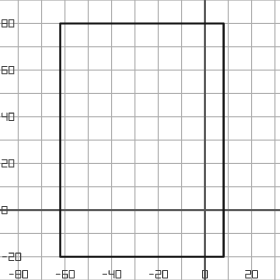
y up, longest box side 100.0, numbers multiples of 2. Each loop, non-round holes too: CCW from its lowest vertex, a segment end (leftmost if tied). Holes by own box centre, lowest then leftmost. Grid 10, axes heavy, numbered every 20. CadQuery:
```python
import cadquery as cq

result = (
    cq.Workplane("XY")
    .moveTo(-62.0, -20.0)
    .lineTo(8.0, -20.0)
    .lineTo(8.0, 80.0)
    .lineTo(-62.0, 80.0)
    .close()
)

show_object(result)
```